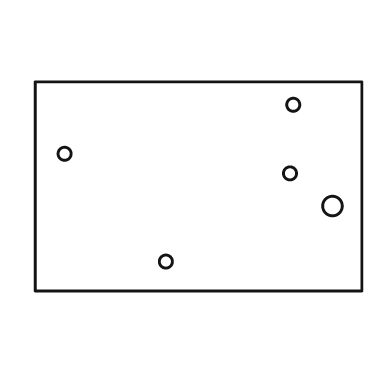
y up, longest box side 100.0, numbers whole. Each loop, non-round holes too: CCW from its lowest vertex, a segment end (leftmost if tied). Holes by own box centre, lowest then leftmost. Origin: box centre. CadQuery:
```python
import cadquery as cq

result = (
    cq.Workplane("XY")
    .moveTo(-50.0, -32.0)
    .lineTo(50.0, -32.0)
    .lineTo(50.0, 32.0)
    .lineTo(-50.0, 32.0)
    .close()
    .moveTo(-10.0, -23.0)
    .circle(2.0)
    .moveTo(41.0, -6.0)
    .circle(3.0)
    .moveTo(28.0, 4.0)
    .circle(2.0)
    .moveTo(-41.0, 10.0)
    .circle(2.0)
    .moveTo(29.0, 25.0)
    .circle(2.0)
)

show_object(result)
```